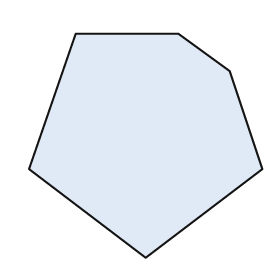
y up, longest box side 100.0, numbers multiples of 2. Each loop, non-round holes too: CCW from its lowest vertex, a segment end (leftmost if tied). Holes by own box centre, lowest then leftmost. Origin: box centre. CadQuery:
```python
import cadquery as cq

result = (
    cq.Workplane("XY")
    .moveTo(0.0, -48.0)
    .lineTo(50.0, -10.0)
    .lineTo(36.0, 32.0)
    .lineTo(14.0, 48.0)
    .lineTo(-30.0, 48.0)
    .lineTo(-50.0, -10.0)
    .close()
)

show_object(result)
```